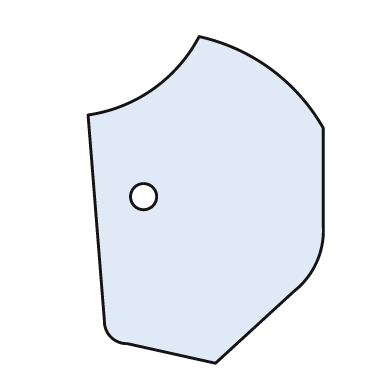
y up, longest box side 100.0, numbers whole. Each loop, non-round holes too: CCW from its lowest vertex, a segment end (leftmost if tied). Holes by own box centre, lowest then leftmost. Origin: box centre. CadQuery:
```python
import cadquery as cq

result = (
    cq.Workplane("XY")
    .moveTo(3.0, -50.0)
    .lineTo(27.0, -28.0)
    .threePointArc((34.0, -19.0), (36.0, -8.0))
    .lineTo(36.0, 22.0)
    .threePointArc((20.0, 40.0), (-2.0, 50.0))
    .threePointArc((-16.0, 34.0), (-36.0, 26.0))
    .lineTo(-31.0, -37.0)
    .threePointArc((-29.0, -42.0), (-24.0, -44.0))
    .close()
    .moveTo(-19.0, 1.0)
    .circle(4.0)
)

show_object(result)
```